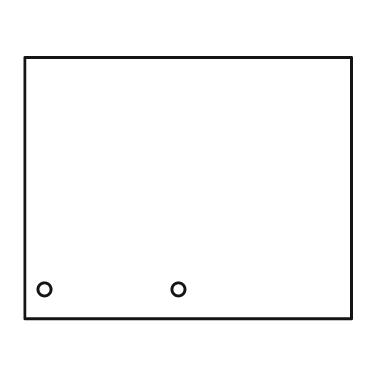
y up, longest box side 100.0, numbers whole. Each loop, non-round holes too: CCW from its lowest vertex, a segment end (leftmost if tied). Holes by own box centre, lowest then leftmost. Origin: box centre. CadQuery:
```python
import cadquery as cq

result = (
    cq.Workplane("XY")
    .moveTo(-50.0, -40.0)
    .lineTo(50.0, -40.0)
    .lineTo(50.0, 40.0)
    .lineTo(-50.0, 40.0)
    .close()
    .moveTo(-44.0, -31.0)
    .circle(2.0)
    .moveTo(-3.0, -31.0)
    .circle(2.0)
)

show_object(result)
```